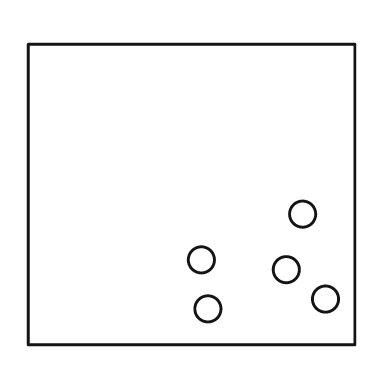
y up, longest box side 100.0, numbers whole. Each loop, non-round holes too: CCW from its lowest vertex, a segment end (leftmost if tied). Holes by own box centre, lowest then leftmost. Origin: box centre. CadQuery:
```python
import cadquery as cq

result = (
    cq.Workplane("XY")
    .moveTo(-50.0, -46.0)
    .lineTo(50.0, -46.0)
    .lineTo(50.0, 46.0)
    .lineTo(-50.0, 46.0)
    .close()
    .moveTo(5.0, -35.0)
    .circle(4.0)
    .moveTo(41.0, -32.0)
    .circle(4.0)
    .moveTo(29.0, -23.0)
    .circle(4.0)
    .moveTo(3.0, -20.0)
    .circle(4.0)
    .moveTo(34.0, -6.0)
    .circle(4.0)
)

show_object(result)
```